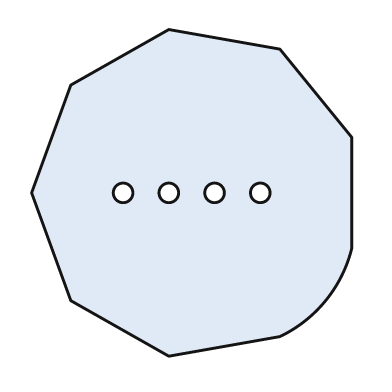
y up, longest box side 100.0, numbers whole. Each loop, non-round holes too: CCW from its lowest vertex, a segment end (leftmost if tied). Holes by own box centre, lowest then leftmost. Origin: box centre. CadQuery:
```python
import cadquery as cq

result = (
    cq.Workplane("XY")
    .moveTo(-7.0, -50.0)
    .lineTo(27.0, -44.0)
    .threePointArc((41.0, -33.0), (49.0, -17.0))
    .lineTo(49.0, 17.0)
    .lineTo(27.0, 44.0)
    .lineTo(-7.0, 50.0)
    .lineTo(-37.0, 33.0)
    .lineTo(-49.0, 0.0)
    .lineTo(-37.0, -33.0)
    .close()
    .moveTo(-21.0, 0.0)
    .circle(3.0)
    .moveTo(-7.0, 0.0)
    .circle(3.0)
    .moveTo(7.0, 0.0)
    .circle(3.0)
    .moveTo(21.0, 0.0)
    .circle(3.0)
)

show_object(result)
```